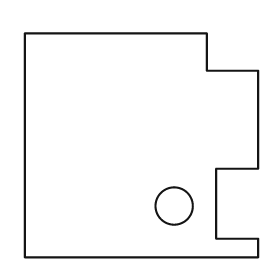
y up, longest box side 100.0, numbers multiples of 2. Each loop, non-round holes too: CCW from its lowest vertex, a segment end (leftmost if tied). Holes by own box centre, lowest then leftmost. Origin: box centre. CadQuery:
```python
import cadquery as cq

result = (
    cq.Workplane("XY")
    .moveTo(-50.0, -48.0)
    .lineTo(50.0, -48.0)
    .lineTo(50.0, -40.0)
    .lineTo(32.0, -40.0)
    .lineTo(32.0, -10.0)
    .lineTo(50.0, -10.0)
    .lineTo(50.0, 32.0)
    .lineTo(28.0, 32.0)
    .lineTo(28.0, 48.0)
    .lineTo(-50.0, 48.0)
    .close()
    .moveTo(14.0, -26.0)
    .circle(8.0)
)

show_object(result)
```